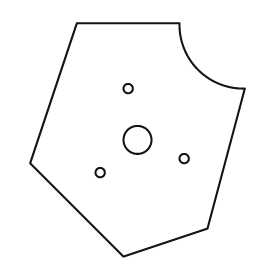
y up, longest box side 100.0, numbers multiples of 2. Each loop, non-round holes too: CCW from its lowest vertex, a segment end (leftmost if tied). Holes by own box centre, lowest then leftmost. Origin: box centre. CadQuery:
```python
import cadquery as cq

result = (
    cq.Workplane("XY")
    .moveTo(-6.0, -50.0)
    .lineTo(30.0, -38.0)
    .lineTo(46.0, 22.0)
    .threePointArc((26.0, 30.0), (18.0, 50.0))
    .lineTo(-26.0, 50.0)
    .lineTo(-46.0, -10.0)
    .close()
    .moveTo(-16.0, -14.0)
    .circle(2.0)
    .moveTo(20.0, -8.0)
    .circle(2.0)
    .moveTo(0.0, 0.0)
    .circle(6.0)
    .moveTo(-4.0, 22.0)
    .circle(2.0)
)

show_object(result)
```